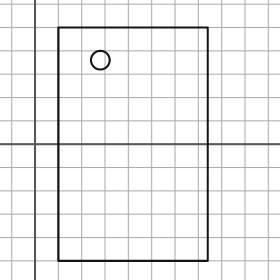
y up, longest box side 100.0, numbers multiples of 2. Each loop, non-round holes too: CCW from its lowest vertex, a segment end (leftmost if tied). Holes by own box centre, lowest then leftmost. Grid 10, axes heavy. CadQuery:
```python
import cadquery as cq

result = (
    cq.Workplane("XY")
    .moveTo(10.0, -50.0)
    .lineTo(74.0, -50.0)
    .lineTo(74.0, 50.0)
    .lineTo(10.0, 50.0)
    .close()
    .moveTo(28.0, 36.0)
    .circle(4.0)
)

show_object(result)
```